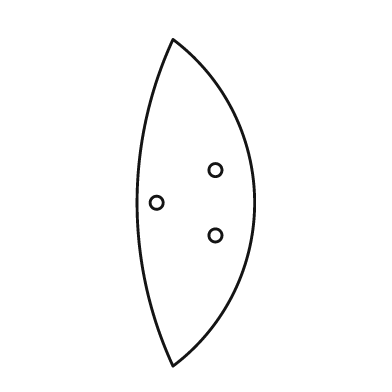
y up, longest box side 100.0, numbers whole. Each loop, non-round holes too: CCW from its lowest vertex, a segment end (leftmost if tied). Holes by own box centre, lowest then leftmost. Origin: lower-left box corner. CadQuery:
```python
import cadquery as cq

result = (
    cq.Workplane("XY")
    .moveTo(11.0, 0.0)
    .threePointArc((36.0, 50.0), (11.0, 100.0))
    .threePointArc((0.0, 50.0), (11.0, 0.0))
    .close()
    .moveTo(24.0, 40.0)
    .circle(2.0)
    .moveTo(6.0, 50.0)
    .circle(2.0)
    .moveTo(24.0, 60.0)
    .circle(2.0)
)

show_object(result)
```